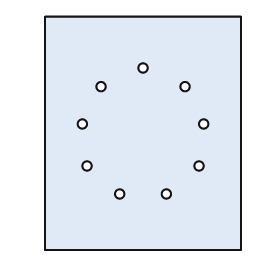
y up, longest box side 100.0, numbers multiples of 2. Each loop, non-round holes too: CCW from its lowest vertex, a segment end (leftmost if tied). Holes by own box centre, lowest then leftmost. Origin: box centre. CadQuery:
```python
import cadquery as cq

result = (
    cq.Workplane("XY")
    .moveTo(-42.0, -50.0)
    .lineTo(42.0, -50.0)
    .lineTo(42.0, 50.0)
    .lineTo(-42.0, 50.0)
    .close()
    .moveTo(-10.0, -26.0)
    .circle(2.0)
    .moveTo(10.0, -26.0)
    .circle(2.0)
    .moveTo(-24.0, -14.0)
    .circle(2.0)
    .moveTo(24.0, -14.0)
    .circle(2.0)
    .moveTo(-26.0, 4.0)
    .circle(2.0)
    .moveTo(26.0, 4.0)
    .circle(2.0)
    .moveTo(-18.0, 20.0)
    .circle(2.0)
    .moveTo(18.0, 20.0)
    .circle(2.0)
    .moveTo(0.0, 28.0)
    .circle(2.0)
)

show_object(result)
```